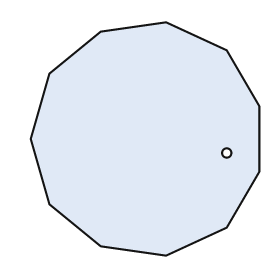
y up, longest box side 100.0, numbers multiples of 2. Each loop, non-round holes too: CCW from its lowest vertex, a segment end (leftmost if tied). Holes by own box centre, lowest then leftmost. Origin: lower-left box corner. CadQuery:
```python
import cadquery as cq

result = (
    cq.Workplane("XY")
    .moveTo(58.0, 0.0)
    .lineTo(84.0, 12.0)
    .lineTo(98.0, 36.0)
    .lineTo(98.0, 64.0)
    .lineTo(84.0, 88.0)
    .lineTo(58.0, 100.0)
    .lineTo(30.0, 96.0)
    .lineTo(8.0, 78.0)
    .lineTo(0.0, 50.0)
    .lineTo(8.0, 22.0)
    .lineTo(30.0, 4.0)
    .close()
    .moveTo(84.0, 44.0)
    .circle(2.0)
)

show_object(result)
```